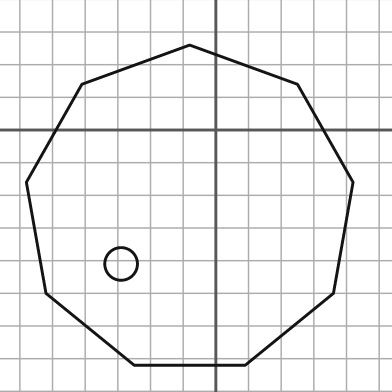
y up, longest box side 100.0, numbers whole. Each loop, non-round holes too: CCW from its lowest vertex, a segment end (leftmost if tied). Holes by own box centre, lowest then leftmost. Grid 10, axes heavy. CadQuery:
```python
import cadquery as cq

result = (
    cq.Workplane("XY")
    .moveTo(-25.0, -72.0)
    .lineTo(9.0, -72.0)
    .lineTo(36.0, -50.0)
    .lineTo(42.0, -16.0)
    .lineTo(25.0, 14.0)
    .lineTo(-8.0, 26.0)
    .lineTo(-41.0, 14.0)
    .lineTo(-58.0, -16.0)
    .lineTo(-52.0, -50.0)
    .close()
    .moveTo(-29.0, -41.0)
    .circle(5.0)
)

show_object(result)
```